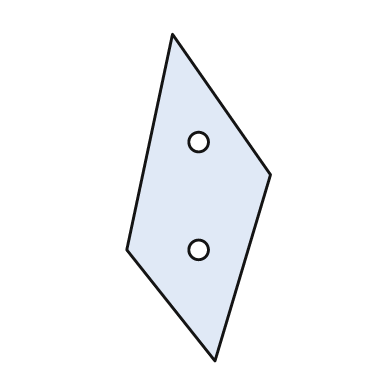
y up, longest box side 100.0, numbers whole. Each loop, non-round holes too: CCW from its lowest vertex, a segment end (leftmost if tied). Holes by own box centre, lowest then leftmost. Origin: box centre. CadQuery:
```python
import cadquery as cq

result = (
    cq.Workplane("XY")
    .moveTo(5.0, -50.0)
    .lineTo(22.0, 7.0)
    .lineTo(-8.0, 50.0)
    .lineTo(-22.0, -16.0)
    .close()
    .moveTo(0.0, -16.0)
    .circle(3.0)
    .moveTo(0.0, 17.0)
    .circle(3.0)
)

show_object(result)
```